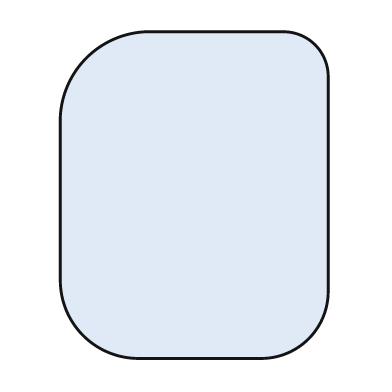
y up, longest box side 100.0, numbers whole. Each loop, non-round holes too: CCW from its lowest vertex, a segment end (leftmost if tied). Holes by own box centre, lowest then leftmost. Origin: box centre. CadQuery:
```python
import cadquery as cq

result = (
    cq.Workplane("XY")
    .moveTo(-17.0, -50.0)
    .lineTo(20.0, -50.0)
    .threePointArc((35.0, -44.0), (41.0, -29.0))
    .lineTo(41.0, 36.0)
    .threePointArc((37.0, 46.0), (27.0, 50.0))
    .lineTo(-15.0, 50.0)
    .threePointArc((-33.0, 42.0), (-41.0, 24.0))
    .lineTo(-41.0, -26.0)
    .threePointArc((-34.0, -43.0), (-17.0, -50.0))
    .close()
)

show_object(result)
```